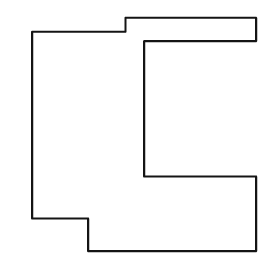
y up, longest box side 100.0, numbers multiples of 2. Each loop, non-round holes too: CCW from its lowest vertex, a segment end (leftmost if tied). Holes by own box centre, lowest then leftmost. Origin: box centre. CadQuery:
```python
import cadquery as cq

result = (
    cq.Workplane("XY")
    .moveTo(-24.0, -50.0)
    .lineTo(48.0, -50.0)
    .lineTo(48.0, -18.0)
    .lineTo(0.0, -18.0)
    .lineTo(0.0, 40.0)
    .lineTo(48.0, 40.0)
    .lineTo(48.0, 50.0)
    .lineTo(-8.0, 50.0)
    .lineTo(-8.0, 44.0)
    .lineTo(-48.0, 44.0)
    .lineTo(-48.0, -36.0)
    .lineTo(-24.0, -36.0)
    .close()
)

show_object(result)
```